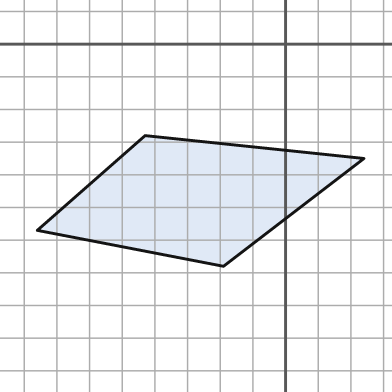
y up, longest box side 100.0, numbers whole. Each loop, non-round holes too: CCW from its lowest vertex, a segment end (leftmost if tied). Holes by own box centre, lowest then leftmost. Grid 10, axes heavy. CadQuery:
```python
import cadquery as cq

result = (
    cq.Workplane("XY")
    .moveTo(-19.0, -68.0)
    .lineTo(24.0, -35.0)
    .lineTo(-43.0, -28.0)
    .lineTo(-76.0, -57.0)
    .close()
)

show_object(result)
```